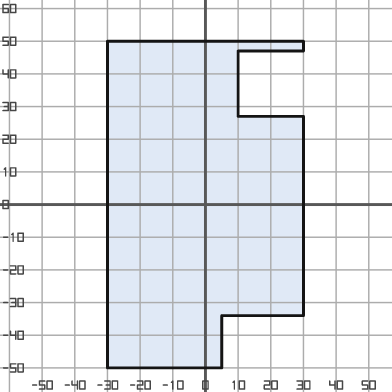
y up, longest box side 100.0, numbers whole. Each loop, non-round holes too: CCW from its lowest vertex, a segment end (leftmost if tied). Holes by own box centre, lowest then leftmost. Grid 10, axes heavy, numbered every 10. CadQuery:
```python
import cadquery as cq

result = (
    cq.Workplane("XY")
    .moveTo(-30.0, -50.0)
    .lineTo(5.0, -50.0)
    .lineTo(5.0, -34.0)
    .lineTo(30.0, -34.0)
    .lineTo(30.0, 27.0)
    .lineTo(10.0, 27.0)
    .lineTo(10.0, 47.0)
    .lineTo(30.0, 47.0)
    .lineTo(30.0, 50.0)
    .lineTo(-30.0, 50.0)
    .close()
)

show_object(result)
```